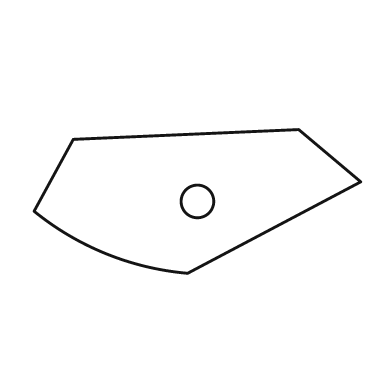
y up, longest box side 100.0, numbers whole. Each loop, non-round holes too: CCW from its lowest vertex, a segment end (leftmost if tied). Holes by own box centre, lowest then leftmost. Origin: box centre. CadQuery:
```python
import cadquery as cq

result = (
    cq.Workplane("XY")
    .moveTo(-3.0, -22.0)
    .lineTo(50.0, 6.0)
    .lineTo(31.0, 22.0)
    .lineTo(-38.0, 19.0)
    .lineTo(-50.0, -3.0)
    .threePointArc((-28.0, -16.0), (-3.0, -22.0))
    .close()
    .moveTo(0.0, 0.0)
    .circle(5.0)
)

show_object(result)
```